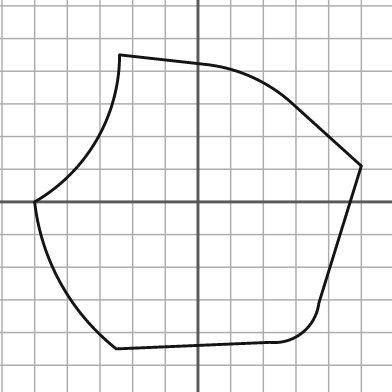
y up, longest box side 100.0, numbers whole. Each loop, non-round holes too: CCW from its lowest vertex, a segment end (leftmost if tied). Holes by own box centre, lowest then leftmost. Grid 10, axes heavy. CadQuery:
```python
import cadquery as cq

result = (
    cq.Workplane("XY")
    .moveTo(-25.0, -45.0)
    .lineTo(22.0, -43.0)
    .threePointArc((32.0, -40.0), (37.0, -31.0))
    .lineTo(50.0, 11.0)
    .lineTo(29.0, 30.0)
    .threePointArc((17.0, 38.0), (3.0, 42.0))
    .lineTo(-24.0, 45.0)
    .threePointArc((-31.0, 19.0), (-50.0, 0.0))
    .threePointArc((-42.0, -25.0), (-25.0, -45.0))
    .close()
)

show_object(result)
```